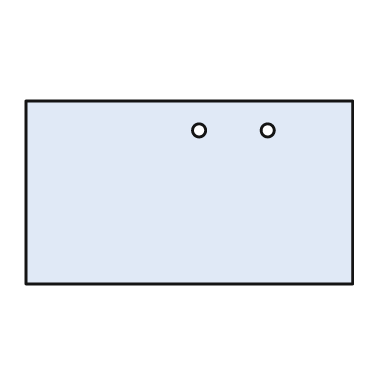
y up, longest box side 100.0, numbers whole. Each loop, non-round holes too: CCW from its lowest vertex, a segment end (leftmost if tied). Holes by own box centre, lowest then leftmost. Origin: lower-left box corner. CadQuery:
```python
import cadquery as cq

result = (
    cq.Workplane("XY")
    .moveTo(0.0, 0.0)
    .lineTo(100.0, 0.0)
    .lineTo(100.0, 56.0)
    .lineTo(0.0, 56.0)
    .close()
    .moveTo(53.0, 47.0)
    .circle(2.0)
    .moveTo(74.0, 47.0)
    .circle(2.0)
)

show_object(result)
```